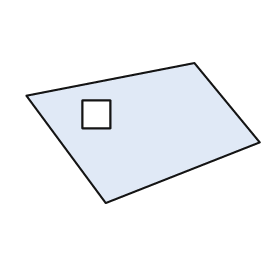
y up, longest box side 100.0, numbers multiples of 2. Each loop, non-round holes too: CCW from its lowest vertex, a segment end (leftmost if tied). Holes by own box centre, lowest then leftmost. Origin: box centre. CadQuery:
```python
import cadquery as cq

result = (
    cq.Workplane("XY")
    .moveTo(-16.0, -30.0)
    .lineTo(50.0, -4.0)
    .lineTo(22.0, 30.0)
    .lineTo(-50.0, 16.0)
    .close()
    .moveTo(-26.0, 2.0)
    .lineTo(-14.0, 2.0)
    .lineTo(-14.0, 14.0)
    .lineTo(-26.0, 14.0)
    .close()
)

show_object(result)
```